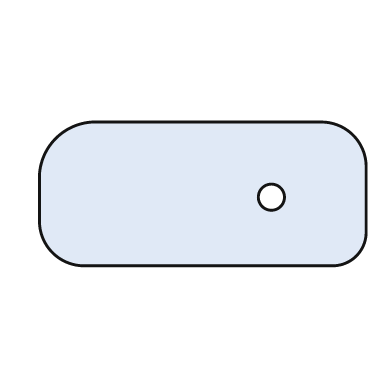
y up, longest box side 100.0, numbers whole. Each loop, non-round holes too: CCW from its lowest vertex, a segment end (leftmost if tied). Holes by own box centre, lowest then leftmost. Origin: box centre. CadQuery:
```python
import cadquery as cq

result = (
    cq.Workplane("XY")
    .moveTo(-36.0, -22.0)
    .lineTo(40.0, -22.0)
    .threePointArc((47.0, -19.0), (50.0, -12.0))
    .lineTo(50.0, 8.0)
    .threePointArc((46.0, 18.0), (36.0, 22.0))
    .lineTo(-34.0, 22.0)
    .threePointArc((-45.0, 17.0), (-50.0, 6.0))
    .lineTo(-50.0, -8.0)
    .threePointArc((-46.0, -18.0), (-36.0, -22.0))
    .close()
    .moveTo(21.0, -1.0)
    .circle(4.0)
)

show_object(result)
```